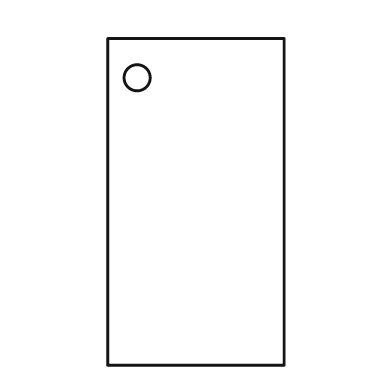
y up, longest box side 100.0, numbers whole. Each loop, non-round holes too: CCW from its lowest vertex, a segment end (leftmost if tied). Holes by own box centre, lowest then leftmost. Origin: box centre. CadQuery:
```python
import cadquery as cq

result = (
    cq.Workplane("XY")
    .moveTo(-27.0, -50.0)
    .lineTo(27.0, -50.0)
    .lineTo(27.0, 50.0)
    .lineTo(-27.0, 50.0)
    .close()
    .moveTo(-18.0, 38.0)
    .circle(4.0)
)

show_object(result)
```